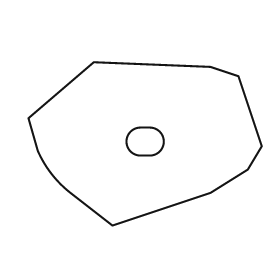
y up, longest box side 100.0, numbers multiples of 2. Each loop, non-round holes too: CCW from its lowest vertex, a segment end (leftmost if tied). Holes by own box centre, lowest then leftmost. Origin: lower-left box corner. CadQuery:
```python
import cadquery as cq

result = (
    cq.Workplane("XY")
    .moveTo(36.0, 0.0)
    .lineTo(78.0, 14.0)
    .lineTo(94.0, 24.0)
    .lineTo(100.0, 34.0)
    .lineTo(90.0, 64.0)
    .lineTo(78.0, 68.0)
    .lineTo(28.0, 70.0)
    .lineTo(0.0, 46.0)
    .lineTo(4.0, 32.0)
    .threePointArc((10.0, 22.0), (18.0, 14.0))
    .close()
    .moveTo(48.0, 30.0)
    .lineTo(52.0, 30.0)
    .threePointArc((58.0, 36.0), (52.0, 42.0))
    .lineTo(48.0, 42.0)
    .threePointArc((42.0, 36.0), (48.0, 30.0))
    .close()
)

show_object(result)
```